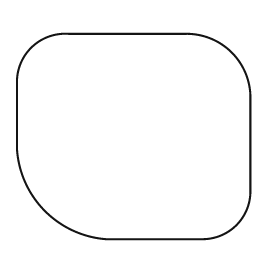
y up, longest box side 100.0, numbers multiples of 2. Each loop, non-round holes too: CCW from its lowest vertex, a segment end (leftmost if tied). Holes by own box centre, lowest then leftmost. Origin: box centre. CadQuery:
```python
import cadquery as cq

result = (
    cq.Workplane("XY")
    .moveTo(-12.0, -44.0)
    .lineTo(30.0, -44.0)
    .threePointArc((44.0, -38.0), (50.0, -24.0))
    .lineTo(50.0, 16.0)
    .threePointArc((42.0, 36.0), (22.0, 44.0))
    .lineTo(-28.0, 44.0)
    .threePointArc((-44.0, 38.0), (-50.0, 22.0))
    .lineTo(-50.0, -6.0)
    .threePointArc((-38.0, -32.0), (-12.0, -44.0))
    .close()
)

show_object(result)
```